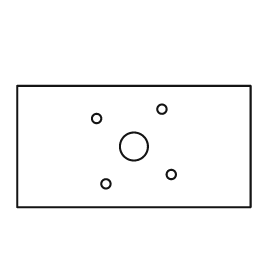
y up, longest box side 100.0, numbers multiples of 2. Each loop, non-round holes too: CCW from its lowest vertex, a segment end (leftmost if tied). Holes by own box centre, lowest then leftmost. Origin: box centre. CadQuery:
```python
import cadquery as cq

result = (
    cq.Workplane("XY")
    .moveTo(-50.0, -26.0)
    .lineTo(50.0, -26.0)
    .lineTo(50.0, 26.0)
    .lineTo(-50.0, 26.0)
    .close()
    .moveTo(-12.0, -16.0)
    .circle(2.0)
    .moveTo(16.0, -12.0)
    .circle(2.0)
    .moveTo(0.0, 0.0)
    .circle(6.0)
    .moveTo(-16.0, 12.0)
    .circle(2.0)
    .moveTo(12.0, 16.0)
    .circle(2.0)
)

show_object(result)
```